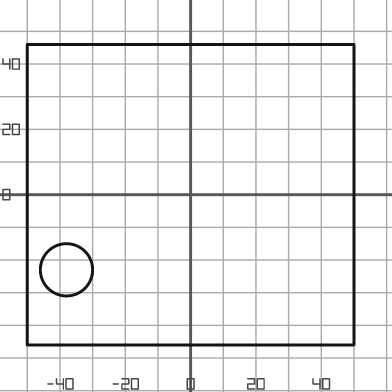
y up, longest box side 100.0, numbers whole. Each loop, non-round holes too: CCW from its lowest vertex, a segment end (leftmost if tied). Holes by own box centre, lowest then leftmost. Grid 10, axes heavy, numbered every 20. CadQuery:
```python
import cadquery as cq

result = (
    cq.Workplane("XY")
    .moveTo(-50.0, -46.0)
    .lineTo(50.0, -46.0)
    .lineTo(50.0, 46.0)
    .lineTo(-50.0, 46.0)
    .close()
    .moveTo(-38.0, -23.0)
    .circle(8.0)
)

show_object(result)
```